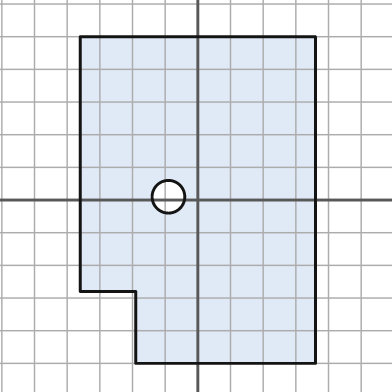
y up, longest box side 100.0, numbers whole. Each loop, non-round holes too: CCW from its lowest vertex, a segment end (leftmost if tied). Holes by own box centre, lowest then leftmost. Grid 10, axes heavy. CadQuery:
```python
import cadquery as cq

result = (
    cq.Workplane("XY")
    .moveTo(-19.0, -50.0)
    .lineTo(36.0, -50.0)
    .lineTo(36.0, 50.0)
    .lineTo(-36.0, 50.0)
    .lineTo(-36.0, -28.0)
    .lineTo(-19.0, -28.0)
    .close()
    .moveTo(-9.0, 1.0)
    .circle(5.0)
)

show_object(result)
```